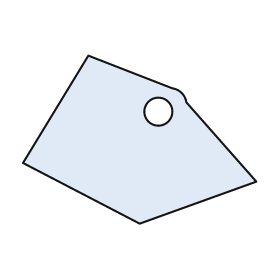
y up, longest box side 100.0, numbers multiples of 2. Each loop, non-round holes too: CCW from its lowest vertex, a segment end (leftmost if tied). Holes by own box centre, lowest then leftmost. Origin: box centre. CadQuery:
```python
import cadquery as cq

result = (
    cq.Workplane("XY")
    .moveTo(0.0, -36.0)
    .lineTo(50.0, -18.0)
    .lineTo(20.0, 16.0)
    .threePointArc((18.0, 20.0), (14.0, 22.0))
    .lineTo(-22.0, 36.0)
    .lineTo(-50.0, -10.0)
    .close()
    .moveTo(8.0, 12.0)
    .circle(6.0)
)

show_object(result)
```